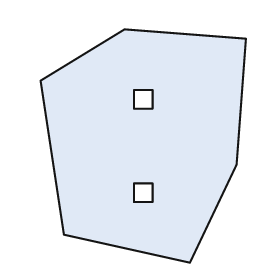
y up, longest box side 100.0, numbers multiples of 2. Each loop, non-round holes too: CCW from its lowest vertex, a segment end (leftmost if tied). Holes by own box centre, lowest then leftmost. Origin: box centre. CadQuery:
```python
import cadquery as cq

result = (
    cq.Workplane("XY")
    .moveTo(20.0, -50.0)
    .lineTo(40.0, -8.0)
    .lineTo(44.0, 46.0)
    .lineTo(-8.0, 50.0)
    .lineTo(-44.0, 28.0)
    .lineTo(-34.0, -38.0)
    .close()
    .moveTo(-4.0, -24.0)
    .lineTo(4.0, -24.0)
    .lineTo(4.0, -16.0)
    .lineTo(-4.0, -16.0)
    .close()
    .moveTo(-4.0, 16.0)
    .lineTo(4.0, 16.0)
    .lineTo(4.0, 24.0)
    .lineTo(-4.0, 24.0)
    .close()
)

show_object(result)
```